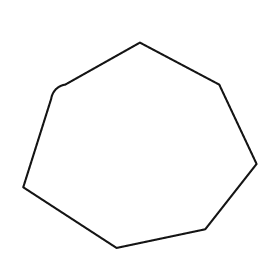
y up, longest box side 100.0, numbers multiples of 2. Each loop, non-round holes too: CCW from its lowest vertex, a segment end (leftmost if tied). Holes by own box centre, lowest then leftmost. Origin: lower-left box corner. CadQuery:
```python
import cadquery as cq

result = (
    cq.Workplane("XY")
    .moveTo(40.0, 0.0)
    .lineTo(78.0, 8.0)
    .lineTo(100.0, 36.0)
    .lineTo(84.0, 70.0)
    .lineTo(50.0, 88.0)
    .lineTo(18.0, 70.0)
    .threePointArc((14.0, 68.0), (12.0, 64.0))
    .lineTo(0.0, 26.0)
    .close()
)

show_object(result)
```